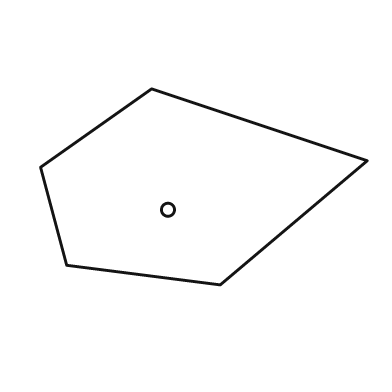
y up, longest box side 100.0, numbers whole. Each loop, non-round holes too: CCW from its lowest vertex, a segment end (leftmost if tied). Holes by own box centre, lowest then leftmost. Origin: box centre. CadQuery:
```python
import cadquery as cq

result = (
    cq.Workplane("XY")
    .moveTo(5.0, -30.0)
    .lineTo(50.0, 8.0)
    .lineTo(-16.0, 30.0)
    .lineTo(-50.0, 6.0)
    .lineTo(-42.0, -24.0)
    .close()
    .moveTo(-11.0, -7.0)
    .circle(2.0)
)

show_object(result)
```